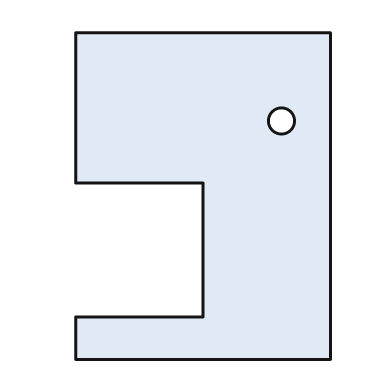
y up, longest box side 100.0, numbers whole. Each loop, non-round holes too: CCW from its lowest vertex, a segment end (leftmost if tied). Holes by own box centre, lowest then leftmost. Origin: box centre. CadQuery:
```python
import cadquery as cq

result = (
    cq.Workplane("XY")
    .moveTo(-39.0, -50.0)
    .lineTo(39.0, -50.0)
    .lineTo(39.0, 50.0)
    .lineTo(-39.0, 50.0)
    .lineTo(-39.0, 4.0)
    .lineTo(0.0, 4.0)
    .lineTo(0.0, -37.0)
    .lineTo(-39.0, -37.0)
    .close()
    .moveTo(24.0, 23.0)
    .circle(4.0)
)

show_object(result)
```